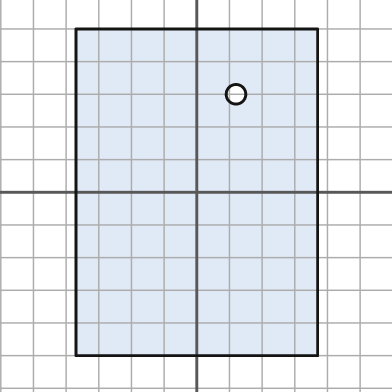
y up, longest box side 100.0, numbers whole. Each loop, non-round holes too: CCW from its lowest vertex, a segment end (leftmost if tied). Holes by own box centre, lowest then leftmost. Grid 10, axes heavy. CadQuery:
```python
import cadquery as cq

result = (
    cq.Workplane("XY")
    .moveTo(-37.0, -50.0)
    .lineTo(37.0, -50.0)
    .lineTo(37.0, 50.0)
    .lineTo(-37.0, 50.0)
    .close()
    .moveTo(12.0, 30.0)
    .circle(3.0)
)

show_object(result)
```